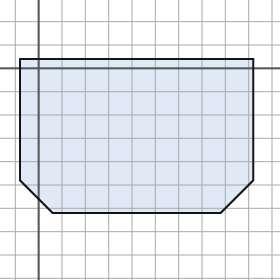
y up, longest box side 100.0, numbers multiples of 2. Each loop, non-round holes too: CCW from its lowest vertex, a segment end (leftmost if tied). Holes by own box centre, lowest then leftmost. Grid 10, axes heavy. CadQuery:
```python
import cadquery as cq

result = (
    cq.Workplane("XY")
    .moveTo(6.0, -62.0)
    .lineTo(78.0, -62.0)
    .lineTo(92.0, -48.0)
    .lineTo(92.0, 4.0)
    .lineTo(-8.0, 4.0)
    .lineTo(-8.0, -48.0)
    .close()
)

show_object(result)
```